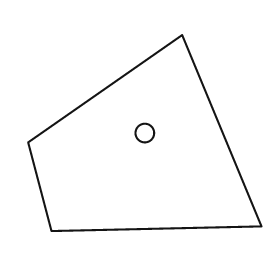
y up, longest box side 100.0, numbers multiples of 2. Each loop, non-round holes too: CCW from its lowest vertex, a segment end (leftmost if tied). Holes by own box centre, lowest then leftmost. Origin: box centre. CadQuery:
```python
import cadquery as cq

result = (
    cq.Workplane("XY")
    .moveTo(-40.0, -42.0)
    .lineTo(50.0, -40.0)
    .lineTo(16.0, 42.0)
    .lineTo(-50.0, -4.0)
    .close()
    .moveTo(0.0, 0.0)
    .circle(4.0)
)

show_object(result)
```